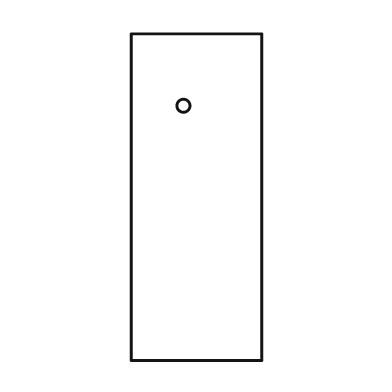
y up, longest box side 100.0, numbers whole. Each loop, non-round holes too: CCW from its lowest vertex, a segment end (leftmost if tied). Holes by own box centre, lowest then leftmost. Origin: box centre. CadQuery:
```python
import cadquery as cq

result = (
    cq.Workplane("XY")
    .moveTo(-20.0, -50.0)
    .lineTo(20.0, -50.0)
    .lineTo(20.0, 50.0)
    .lineTo(-20.0, 50.0)
    .close()
    .moveTo(-4.0, 28.0)
    .circle(2.0)
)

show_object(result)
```